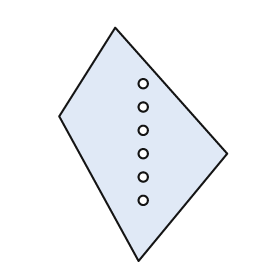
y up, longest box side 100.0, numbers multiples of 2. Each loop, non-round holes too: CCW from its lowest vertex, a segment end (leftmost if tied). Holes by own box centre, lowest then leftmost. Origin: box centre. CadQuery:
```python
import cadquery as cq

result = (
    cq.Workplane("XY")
    .moveTo(-2.0, -50.0)
    .lineTo(36.0, -4.0)
    .lineTo(-12.0, 50.0)
    .lineTo(-36.0, 12.0)
    .close()
    .moveTo(0.0, -24.0)
    .circle(2.0)
    .moveTo(0.0, -14.0)
    .circle(2.0)
    .moveTo(0.0, -4.0)
    .circle(2.0)
    .moveTo(0.0, 6.0)
    .circle(2.0)
    .moveTo(0.0, 16.0)
    .circle(2.0)
    .moveTo(0.0, 26.0)
    .circle(2.0)
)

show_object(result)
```